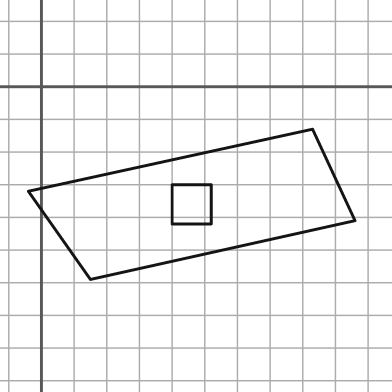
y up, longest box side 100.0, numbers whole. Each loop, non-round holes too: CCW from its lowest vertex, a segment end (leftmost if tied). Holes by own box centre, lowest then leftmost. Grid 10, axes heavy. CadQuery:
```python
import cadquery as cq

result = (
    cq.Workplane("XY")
    .moveTo(15.0, -59.0)
    .lineTo(96.0, -41.0)
    .lineTo(83.0, -13.0)
    .lineTo(-4.0, -32.0)
    .close()
    .moveTo(40.0, -42.0)
    .lineTo(52.0, -42.0)
    .lineTo(52.0, -30.0)
    .lineTo(40.0, -30.0)
    .close()
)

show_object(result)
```